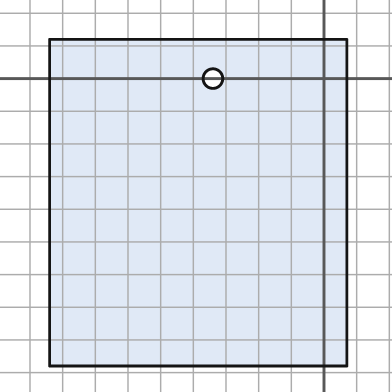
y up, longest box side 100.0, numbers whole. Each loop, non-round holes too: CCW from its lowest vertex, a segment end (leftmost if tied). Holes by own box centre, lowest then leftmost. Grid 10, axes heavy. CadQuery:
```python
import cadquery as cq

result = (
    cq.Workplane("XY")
    .moveTo(-84.0, -88.0)
    .lineTo(7.0, -88.0)
    .lineTo(7.0, 12.0)
    .lineTo(-84.0, 12.0)
    .close()
    .moveTo(-34.0, 0.0)
    .circle(3.0)
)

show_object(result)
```